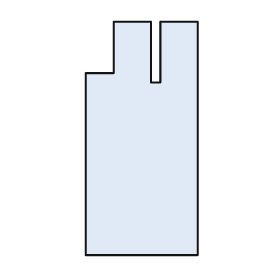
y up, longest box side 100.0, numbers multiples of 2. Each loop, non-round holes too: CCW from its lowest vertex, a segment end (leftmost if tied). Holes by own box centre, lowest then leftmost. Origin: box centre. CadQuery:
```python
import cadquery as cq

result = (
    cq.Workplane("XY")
    .moveTo(-24.0, -50.0)
    .lineTo(24.0, -50.0)
    .lineTo(24.0, 50.0)
    .lineTo(8.0, 50.0)
    .lineTo(8.0, 24.0)
    .lineTo(4.0, 24.0)
    .lineTo(4.0, 50.0)
    .lineTo(-12.0, 50.0)
    .lineTo(-12.0, 28.0)
    .lineTo(-24.0, 28.0)
    .close()
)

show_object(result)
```